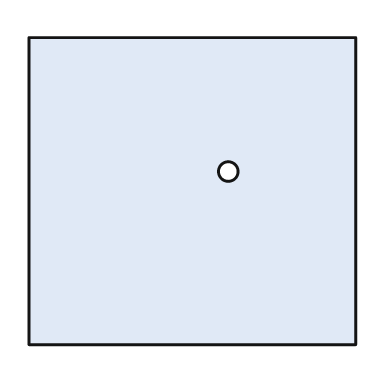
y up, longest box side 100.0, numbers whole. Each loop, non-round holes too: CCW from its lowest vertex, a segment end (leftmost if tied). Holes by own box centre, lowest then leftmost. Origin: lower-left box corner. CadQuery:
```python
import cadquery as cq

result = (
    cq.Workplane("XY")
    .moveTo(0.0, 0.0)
    .lineTo(100.0, 0.0)
    .lineTo(100.0, 94.0)
    .lineTo(0.0, 94.0)
    .close()
    .moveTo(61.0, 53.0)
    .circle(3.0)
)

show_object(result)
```